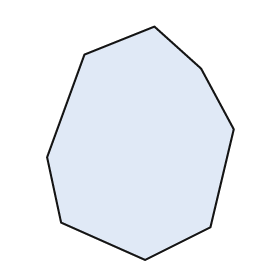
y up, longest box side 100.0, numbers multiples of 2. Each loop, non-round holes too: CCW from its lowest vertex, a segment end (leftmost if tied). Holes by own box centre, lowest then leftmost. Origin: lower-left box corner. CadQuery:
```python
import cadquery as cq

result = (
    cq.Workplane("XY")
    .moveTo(42.0, 0.0)
    .lineTo(70.0, 14.0)
    .lineTo(80.0, 56.0)
    .lineTo(66.0, 82.0)
    .lineTo(46.0, 100.0)
    .lineTo(16.0, 88.0)
    .lineTo(0.0, 44.0)
    .lineTo(6.0, 16.0)
    .close()
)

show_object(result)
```